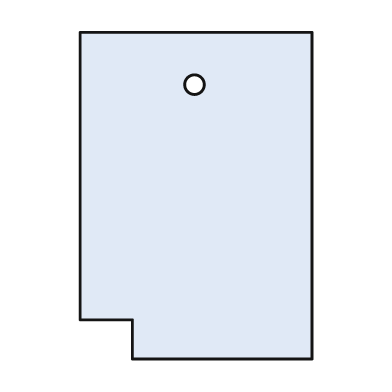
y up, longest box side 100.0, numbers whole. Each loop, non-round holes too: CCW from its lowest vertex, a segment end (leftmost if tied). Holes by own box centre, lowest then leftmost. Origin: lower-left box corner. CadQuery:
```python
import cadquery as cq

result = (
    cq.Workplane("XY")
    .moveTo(16.0, 0.0)
    .lineTo(71.0, 0.0)
    .lineTo(71.0, 100.0)
    .lineTo(0.0, 100.0)
    .lineTo(0.0, 12.0)
    .lineTo(16.0, 12.0)
    .close()
    .moveTo(35.0, 84.0)
    .circle(3.0)
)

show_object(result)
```